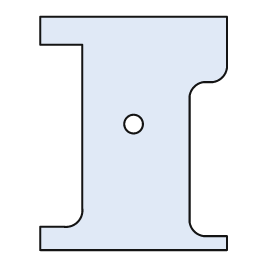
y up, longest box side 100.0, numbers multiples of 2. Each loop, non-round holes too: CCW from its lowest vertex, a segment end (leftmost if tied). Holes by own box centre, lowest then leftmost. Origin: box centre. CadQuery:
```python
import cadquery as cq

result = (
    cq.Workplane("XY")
    .moveTo(-40.0, -50.0)
    .lineTo(40.0, -50.0)
    .lineTo(40.0, -44.0)
    .lineTo(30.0, -44.0)
    .threePointArc((26.0, -42.0), (24.0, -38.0))
    .lineTo(24.0, 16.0)
    .threePointArc((26.0, 20.0), (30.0, 22.0))
    .lineTo(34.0, 22.0)
    .threePointArc((38.0, 24.0), (40.0, 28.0))
    .lineTo(40.0, 50.0)
    .lineTo(-40.0, 50.0)
    .lineTo(-40.0, 38.0)
    .lineTo(-22.0, 38.0)
    .lineTo(-22.0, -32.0)
    .threePointArc((-24.0, -38.0), (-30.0, -40.0))
    .lineTo(-40.0, -40.0)
    .close()
    .moveTo(0.0, 4.0)
    .circle(4.0)
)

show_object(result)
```